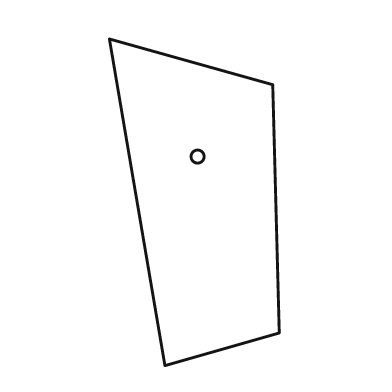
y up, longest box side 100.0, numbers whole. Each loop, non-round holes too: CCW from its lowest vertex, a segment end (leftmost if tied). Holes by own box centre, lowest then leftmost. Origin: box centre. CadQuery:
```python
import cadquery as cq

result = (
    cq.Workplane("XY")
    .moveTo(-9.0, -50.0)
    .lineTo(26.0, -40.0)
    .lineTo(24.0, 36.0)
    .lineTo(-26.0, 50.0)
    .close()
    .moveTo(1.0, 14.0)
    .circle(2.0)
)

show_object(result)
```